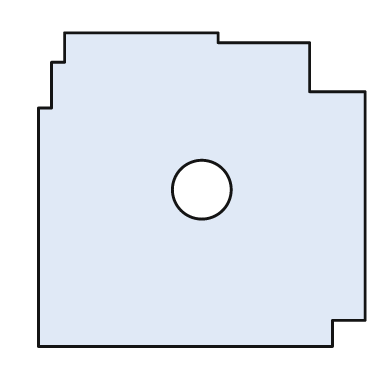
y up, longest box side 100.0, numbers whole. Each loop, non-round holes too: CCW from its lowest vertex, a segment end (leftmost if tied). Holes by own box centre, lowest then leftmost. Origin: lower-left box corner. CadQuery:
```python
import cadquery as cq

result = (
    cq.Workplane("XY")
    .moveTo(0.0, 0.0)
    .lineTo(90.0, 0.0)
    .lineTo(90.0, 8.0)
    .lineTo(100.0, 8.0)
    .lineTo(100.0, 78.0)
    .lineTo(83.0, 78.0)
    .lineTo(83.0, 93.0)
    .lineTo(55.0, 93.0)
    .lineTo(55.0, 96.0)
    .lineTo(8.0, 96.0)
    .lineTo(8.0, 87.0)
    .lineTo(4.0, 87.0)
    .lineTo(4.0, 73.0)
    .lineTo(0.0, 73.0)
    .close()
    .moveTo(50.0, 48.0)
    .circle(9.0)
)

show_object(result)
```